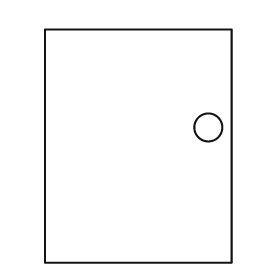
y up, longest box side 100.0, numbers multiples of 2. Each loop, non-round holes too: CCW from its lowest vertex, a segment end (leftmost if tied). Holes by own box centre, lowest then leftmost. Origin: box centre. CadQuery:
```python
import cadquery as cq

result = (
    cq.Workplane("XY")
    .moveTo(-40.0, -50.0)
    .lineTo(40.0, -50.0)
    .lineTo(40.0, 50.0)
    .lineTo(-40.0, 50.0)
    .close()
    .moveTo(30.0, 8.0)
    .circle(6.0)
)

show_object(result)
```